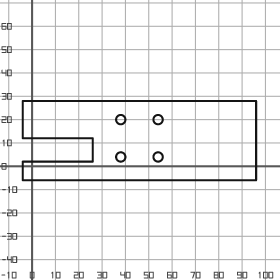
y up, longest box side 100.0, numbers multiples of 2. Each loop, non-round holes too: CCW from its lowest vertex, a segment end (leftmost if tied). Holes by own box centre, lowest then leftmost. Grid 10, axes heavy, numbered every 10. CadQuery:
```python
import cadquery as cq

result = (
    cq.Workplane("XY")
    .moveTo(-4.0, -6.0)
    .lineTo(96.0, -6.0)
    .lineTo(96.0, 28.0)
    .lineTo(-4.0, 28.0)
    .lineTo(-4.0, 12.0)
    .lineTo(26.0, 12.0)
    .lineTo(26.0, 2.0)
    .lineTo(-4.0, 2.0)
    .close()
    .moveTo(38.0, 4.0)
    .circle(2.0)
    .moveTo(54.0, 4.0)
    .circle(2.0)
    .moveTo(38.0, 20.0)
    .circle(2.0)
    .moveTo(54.0, 20.0)
    .circle(2.0)
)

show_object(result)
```